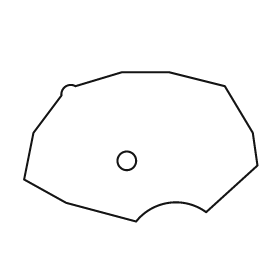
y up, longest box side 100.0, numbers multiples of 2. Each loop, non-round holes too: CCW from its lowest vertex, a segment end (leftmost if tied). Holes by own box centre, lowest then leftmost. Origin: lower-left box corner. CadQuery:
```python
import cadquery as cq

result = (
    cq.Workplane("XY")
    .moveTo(48.0, 0.0)
    .threePointArc((62.0, 8.0), (78.0, 4.0))
    .lineTo(100.0, 24.0)
    .lineTo(98.0, 38.0)
    .lineTo(86.0, 58.0)
    .lineTo(62.0, 64.0)
    .lineTo(42.0, 64.0)
    .lineTo(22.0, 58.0)
    .threePointArc((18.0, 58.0), (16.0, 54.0))
    .lineTo(4.0, 38.0)
    .lineTo(0.0, 18.0)
    .lineTo(18.0, 8.0)
    .close()
    .moveTo(44.0, 26.0)
    .circle(4.0)
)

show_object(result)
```